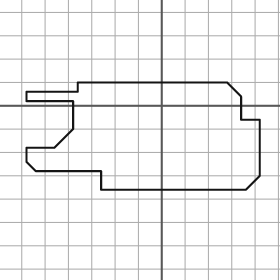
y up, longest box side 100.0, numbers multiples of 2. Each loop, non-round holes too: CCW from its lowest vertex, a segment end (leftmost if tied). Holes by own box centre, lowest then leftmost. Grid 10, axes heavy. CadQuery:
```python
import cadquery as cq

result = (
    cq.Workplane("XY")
    .moveTo(-26.0, -36.0)
    .lineTo(36.0, -36.0)
    .lineTo(42.0, -30.0)
    .lineTo(42.0, -6.0)
    .lineTo(34.0, -6.0)
    .lineTo(34.0, 4.0)
    .lineTo(28.0, 10.0)
    .lineTo(-36.0, 10.0)
    .lineTo(-36.0, 6.0)
    .lineTo(-58.0, 6.0)
    .lineTo(-58.0, 2.0)
    .lineTo(-38.0, 2.0)
    .lineTo(-38.0, -10.0)
    .lineTo(-46.0, -18.0)
    .lineTo(-58.0, -18.0)
    .lineTo(-58.0, -24.0)
    .lineTo(-54.0, -28.0)
    .lineTo(-26.0, -28.0)
    .close()
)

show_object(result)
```